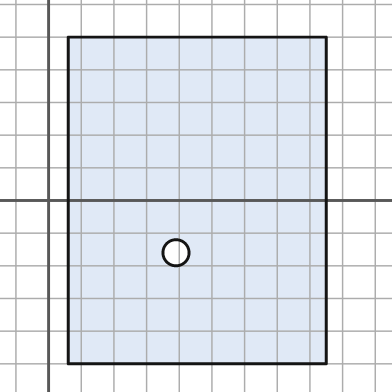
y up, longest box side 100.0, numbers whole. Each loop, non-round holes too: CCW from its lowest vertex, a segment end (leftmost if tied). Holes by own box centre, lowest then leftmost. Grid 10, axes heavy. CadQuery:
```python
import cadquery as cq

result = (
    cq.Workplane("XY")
    .moveTo(6.0, -50.0)
    .lineTo(85.0, -50.0)
    .lineTo(85.0, 50.0)
    .lineTo(6.0, 50.0)
    .close()
    .moveTo(39.0, -16.0)
    .circle(4.0)
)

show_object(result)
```